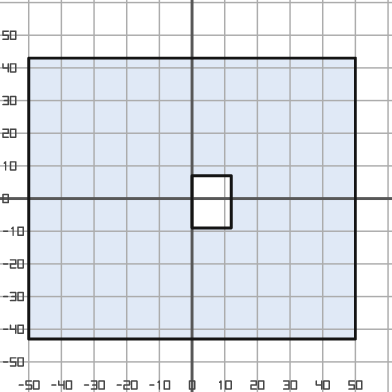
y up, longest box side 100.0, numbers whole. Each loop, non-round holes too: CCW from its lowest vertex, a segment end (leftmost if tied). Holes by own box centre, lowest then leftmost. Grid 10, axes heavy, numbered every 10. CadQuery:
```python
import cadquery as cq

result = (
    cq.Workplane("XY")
    .moveTo(-50.0, -43.0)
    .lineTo(50.0, -43.0)
    .lineTo(50.0, 43.0)
    .lineTo(-50.0, 43.0)
    .close()
    .moveTo(0.0, -9.0)
    .lineTo(12.0, -9.0)
    .lineTo(12.0, 7.0)
    .lineTo(0.0, 7.0)
    .close()
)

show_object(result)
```